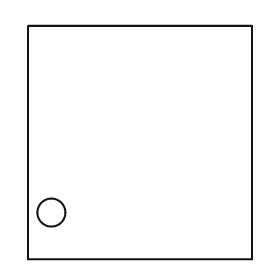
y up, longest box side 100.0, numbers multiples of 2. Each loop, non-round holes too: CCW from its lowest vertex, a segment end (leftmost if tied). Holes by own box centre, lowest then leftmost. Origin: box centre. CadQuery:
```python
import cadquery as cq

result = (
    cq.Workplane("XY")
    .moveTo(-48.0, -50.0)
    .lineTo(48.0, -50.0)
    .lineTo(48.0, 50.0)
    .lineTo(-48.0, 50.0)
    .close()
    .moveTo(-38.0, -30.0)
    .circle(6.0)
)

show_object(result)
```